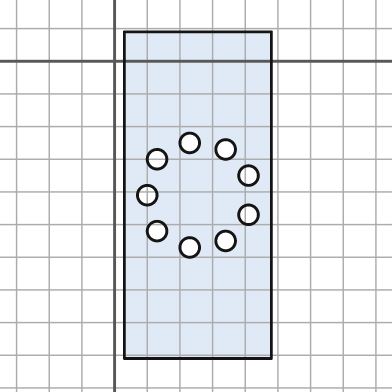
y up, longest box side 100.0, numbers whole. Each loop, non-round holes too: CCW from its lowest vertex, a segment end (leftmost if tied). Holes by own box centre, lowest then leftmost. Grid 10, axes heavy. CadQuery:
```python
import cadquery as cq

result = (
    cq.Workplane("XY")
    .moveTo(3.0, -91.0)
    .lineTo(48.0, -91.0)
    .lineTo(48.0, 9.0)
    .lineTo(3.0, 9.0)
    .close()
    .moveTo(23.0, -57.0)
    .circle(3.0)
    .moveTo(34.0, -55.0)
    .circle(3.0)
    .moveTo(13.0, -52.0)
    .circle(3.0)
    .moveTo(41.0, -47.0)
    .circle(3.0)
    .moveTo(10.0, -41.0)
    .circle(3.0)
    .moveTo(41.0, -35.0)
    .circle(3.0)
    .moveTo(13.0, -30.0)
    .circle(3.0)
    .moveTo(34.0, -27.0)
    .circle(3.0)
    .moveTo(23.0, -25.0)
    .circle(3.0)
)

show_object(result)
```